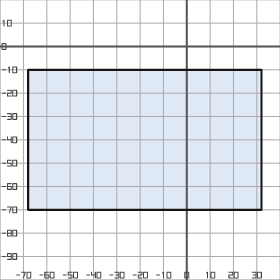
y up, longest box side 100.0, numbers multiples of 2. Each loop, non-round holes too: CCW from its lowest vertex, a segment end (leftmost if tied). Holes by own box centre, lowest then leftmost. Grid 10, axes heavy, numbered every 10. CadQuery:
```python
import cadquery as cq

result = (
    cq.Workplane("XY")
    .moveTo(-68.0, -70.0)
    .lineTo(32.0, -70.0)
    .lineTo(32.0, -10.0)
    .lineTo(-68.0, -10.0)
    .close()
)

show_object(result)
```